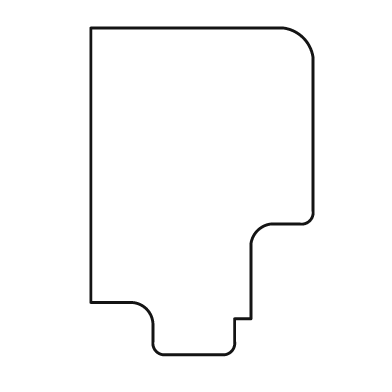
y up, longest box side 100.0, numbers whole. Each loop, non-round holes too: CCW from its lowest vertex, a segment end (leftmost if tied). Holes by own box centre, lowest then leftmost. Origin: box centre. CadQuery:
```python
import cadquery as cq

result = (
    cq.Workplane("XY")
    .moveTo(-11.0, -50.0)
    .lineTo(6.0, -50.0)
    .threePointArc((9.0, -49.0), (10.0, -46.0))
    .lineTo(10.0, -39.0)
    .lineTo(15.0, -39.0)
    .lineTo(15.0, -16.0)
    .threePointArc((17.0, -12.0), (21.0, -10.0))
    .lineTo(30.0, -10.0)
    .threePointArc((33.0, -9.0), (34.0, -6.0))
    .lineTo(34.0, 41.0)
    .threePointArc((31.0, 47.0), (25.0, 50.0))
    .lineTo(-34.0, 50.0)
    .lineTo(-34.0, -34.0)
    .lineTo(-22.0, -34.0)
    .threePointArc((-17.0, -36.0), (-15.0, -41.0))
    .lineTo(-15.0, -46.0)
    .threePointArc((-14.0, -49.0), (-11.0, -50.0))
    .close()
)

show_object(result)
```